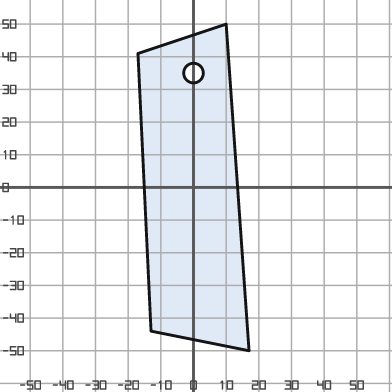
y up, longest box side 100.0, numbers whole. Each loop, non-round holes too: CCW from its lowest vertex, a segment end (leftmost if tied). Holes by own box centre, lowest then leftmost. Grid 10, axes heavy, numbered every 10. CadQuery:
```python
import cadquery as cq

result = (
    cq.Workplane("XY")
    .moveTo(17.0, -50.0)
    .lineTo(10.0, 50.0)
    .lineTo(-17.0, 41.0)
    .lineTo(-13.0, -44.0)
    .close()
    .moveTo(0.0, 35.0)
    .circle(3.0)
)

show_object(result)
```